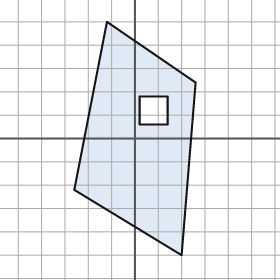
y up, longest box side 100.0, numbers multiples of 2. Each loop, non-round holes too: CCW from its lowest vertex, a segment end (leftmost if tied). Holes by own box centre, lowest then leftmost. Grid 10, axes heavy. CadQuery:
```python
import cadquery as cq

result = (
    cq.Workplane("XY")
    .moveTo(20.0, -50.0)
    .lineTo(26.0, 24.0)
    .lineTo(-12.0, 50.0)
    .lineTo(-26.0, -22.0)
    .close()
    .moveTo(2.0, 6.0)
    .lineTo(14.0, 6.0)
    .lineTo(14.0, 18.0)
    .lineTo(2.0, 18.0)
    .close()
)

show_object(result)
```